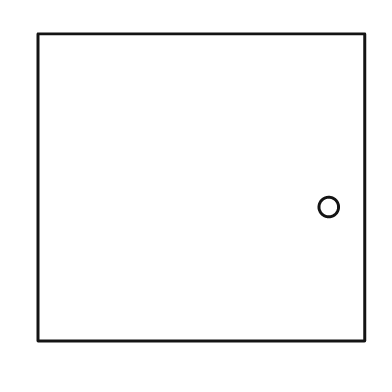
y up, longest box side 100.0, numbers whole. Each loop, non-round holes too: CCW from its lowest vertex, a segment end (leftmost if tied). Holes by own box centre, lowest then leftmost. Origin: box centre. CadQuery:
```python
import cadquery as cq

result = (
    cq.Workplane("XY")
    .moveTo(-50.0, -47.0)
    .lineTo(50.0, -47.0)
    .lineTo(50.0, 47.0)
    .lineTo(-50.0, 47.0)
    .close()
    .moveTo(39.0, -6.0)
    .circle(3.0)
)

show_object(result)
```